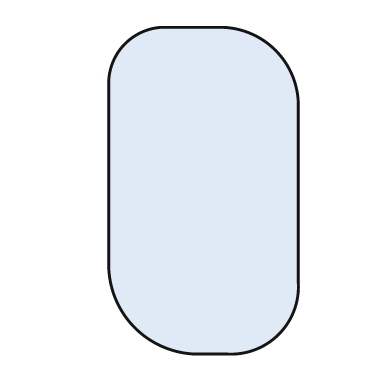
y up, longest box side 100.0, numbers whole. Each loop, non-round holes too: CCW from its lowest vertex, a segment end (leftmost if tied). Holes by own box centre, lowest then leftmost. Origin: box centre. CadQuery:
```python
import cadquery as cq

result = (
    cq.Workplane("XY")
    .moveTo(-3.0, -50.0)
    .lineTo(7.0, -50.0)
    .threePointArc((23.0, -44.0), (29.0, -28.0))
    .lineTo(29.0, 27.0)
    .threePointArc((22.0, 43.0), (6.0, 50.0))
    .lineTo(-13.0, 50.0)
    .threePointArc((-24.0, 45.0), (-29.0, 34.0))
    .lineTo(-29.0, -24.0)
    .threePointArc((-21.0, -42.0), (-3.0, -50.0))
    .close()
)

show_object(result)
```